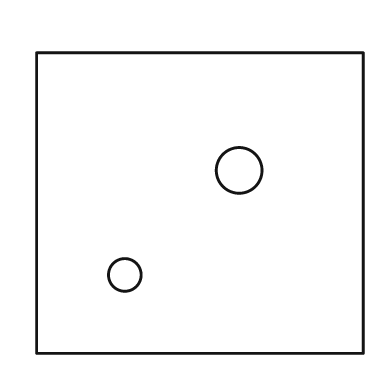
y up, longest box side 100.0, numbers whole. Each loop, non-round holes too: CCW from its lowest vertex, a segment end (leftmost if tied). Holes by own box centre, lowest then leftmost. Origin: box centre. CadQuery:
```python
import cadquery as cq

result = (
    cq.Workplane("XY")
    .moveTo(-50.0, -46.0)
    .lineTo(50.0, -46.0)
    .lineTo(50.0, 46.0)
    .lineTo(-50.0, 46.0)
    .close()
    .moveTo(-23.0, -22.0)
    .circle(5.0)
    .moveTo(12.0, 10.0)
    .circle(7.0)
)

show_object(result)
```